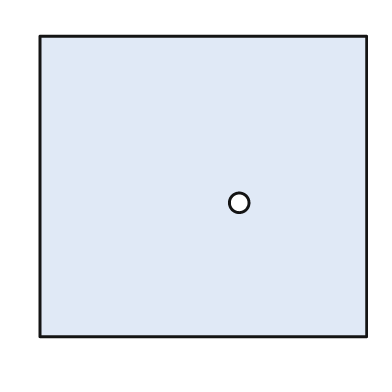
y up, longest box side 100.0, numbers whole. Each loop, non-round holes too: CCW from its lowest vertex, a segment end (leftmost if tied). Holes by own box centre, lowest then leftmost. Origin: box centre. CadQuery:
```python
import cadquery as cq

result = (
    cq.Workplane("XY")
    .moveTo(-50.0, -46.0)
    .lineTo(50.0, -46.0)
    .lineTo(50.0, 46.0)
    .lineTo(-50.0, 46.0)
    .close()
    .moveTo(11.0, -5.0)
    .circle(3.0)
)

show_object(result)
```